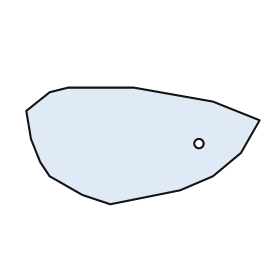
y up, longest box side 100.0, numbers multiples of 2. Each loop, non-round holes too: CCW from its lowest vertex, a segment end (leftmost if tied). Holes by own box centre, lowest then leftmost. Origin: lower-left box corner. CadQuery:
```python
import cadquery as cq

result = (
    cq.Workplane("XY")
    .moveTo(36.0, 0.0)
    .lineTo(66.0, 6.0)
    .lineTo(80.0, 12.0)
    .lineTo(92.0, 22.0)
    .lineTo(100.0, 36.0)
    .lineTo(80.0, 44.0)
    .lineTo(46.0, 50.0)
    .lineTo(18.0, 50.0)
    .lineTo(10.0, 48.0)
    .lineTo(0.0, 40.0)
    .lineTo(2.0, 28.0)
    .lineTo(6.0, 18.0)
    .lineTo(10.0, 12.0)
    .lineTo(24.0, 4.0)
    .close()
    .moveTo(74.0, 26.0)
    .circle(2.0)
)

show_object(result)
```